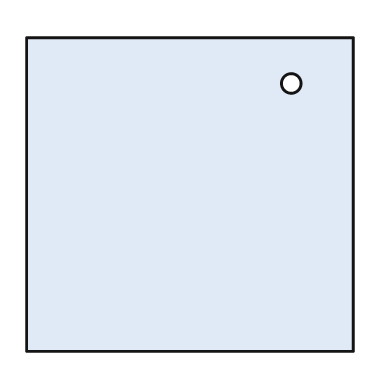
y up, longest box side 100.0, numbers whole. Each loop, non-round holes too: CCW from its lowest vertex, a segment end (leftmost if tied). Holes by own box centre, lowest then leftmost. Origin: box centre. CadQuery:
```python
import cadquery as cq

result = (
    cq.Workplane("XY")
    .moveTo(-50.0, -48.0)
    .lineTo(50.0, -48.0)
    .lineTo(50.0, 48.0)
    .lineTo(-50.0, 48.0)
    .close()
    .moveTo(31.0, 34.0)
    .circle(3.0)
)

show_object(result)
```